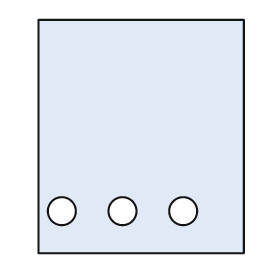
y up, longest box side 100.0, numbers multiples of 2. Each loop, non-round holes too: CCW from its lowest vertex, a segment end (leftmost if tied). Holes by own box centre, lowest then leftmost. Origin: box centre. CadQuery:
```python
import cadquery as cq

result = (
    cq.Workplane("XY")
    .moveTo(-44.0, -50.0)
    .lineTo(44.0, -50.0)
    .lineTo(44.0, 50.0)
    .lineTo(-44.0, 50.0)
    .close()
    .moveTo(-34.0, -32.0)
    .circle(6.0)
    .moveTo(-8.0, -32.0)
    .circle(6.0)
    .moveTo(18.0, -32.0)
    .circle(6.0)
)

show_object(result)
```